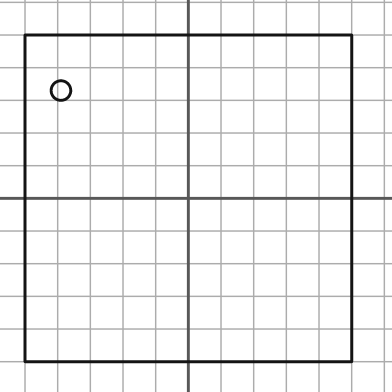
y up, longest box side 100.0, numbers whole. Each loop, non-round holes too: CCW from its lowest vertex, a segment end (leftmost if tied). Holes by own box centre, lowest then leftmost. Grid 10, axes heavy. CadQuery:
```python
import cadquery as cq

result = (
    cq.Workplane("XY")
    .moveTo(-50.0, -50.0)
    .lineTo(50.0, -50.0)
    .lineTo(50.0, 50.0)
    .lineTo(-50.0, 50.0)
    .close()
    .moveTo(-39.0, 33.0)
    .circle(3.0)
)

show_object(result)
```